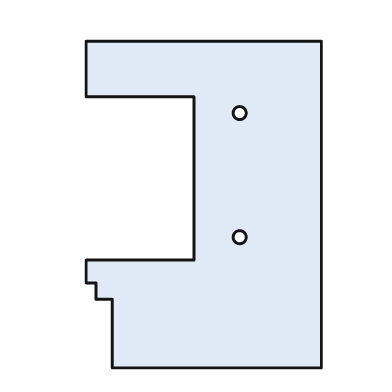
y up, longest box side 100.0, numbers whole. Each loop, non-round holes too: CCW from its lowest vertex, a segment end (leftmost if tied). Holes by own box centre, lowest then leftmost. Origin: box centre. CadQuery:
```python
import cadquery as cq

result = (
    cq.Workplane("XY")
    .moveTo(-28.0, -50.0)
    .lineTo(36.0, -50.0)
    .lineTo(36.0, 50.0)
    .lineTo(-36.0, 50.0)
    .lineTo(-36.0, 33.0)
    .lineTo(-3.0, 33.0)
    .lineTo(-3.0, -17.0)
    .lineTo(-36.0, -17.0)
    .lineTo(-36.0, -24.0)
    .lineTo(-33.0, -24.0)
    .lineTo(-33.0, -29.0)
    .lineTo(-28.0, -29.0)
    .close()
    .moveTo(11.0, -10.0)
    .circle(2.0)
    .moveTo(11.0, 28.0)
    .circle(2.0)
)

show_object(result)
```